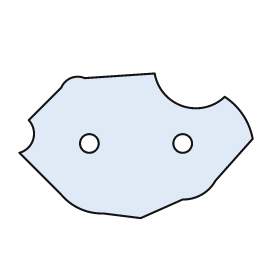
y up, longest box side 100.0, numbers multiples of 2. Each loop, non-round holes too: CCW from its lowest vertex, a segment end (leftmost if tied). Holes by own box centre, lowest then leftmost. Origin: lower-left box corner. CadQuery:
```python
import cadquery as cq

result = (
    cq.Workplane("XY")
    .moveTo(52.0, 0.0)
    .lineTo(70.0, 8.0)
    .threePointArc((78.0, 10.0), (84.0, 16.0))
    .lineTo(100.0, 34.0)
    .threePointArc((96.0, 44.0), (88.0, 52.0))
    .threePointArc((70.0, 48.0), (58.0, 62.0))
    .lineTo(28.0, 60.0)
    .threePointArc((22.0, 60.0), (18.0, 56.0))
    .lineTo(4.0, 42.0)
    .threePointArc((6.0, 34.0), (0.0, 28.0))
    .lineTo(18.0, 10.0)
    .threePointArc((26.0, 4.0), (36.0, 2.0))
    .close()
    .moveTo(30.0, 32.0)
    .circle(4.0)
    .moveTo(70.0, 32.0)
    .circle(4.0)
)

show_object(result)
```